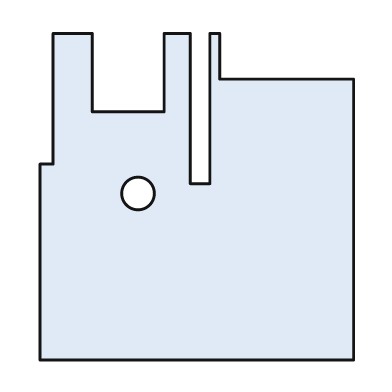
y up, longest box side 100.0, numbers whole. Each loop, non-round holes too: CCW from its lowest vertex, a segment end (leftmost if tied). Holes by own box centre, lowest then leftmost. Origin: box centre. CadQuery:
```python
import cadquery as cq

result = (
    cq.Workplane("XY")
    .moveTo(-48.0, -50.0)
    .lineTo(48.0, -50.0)
    .lineTo(48.0, 36.0)
    .lineTo(7.0, 36.0)
    .lineTo(7.0, 50.0)
    .lineTo(4.0, 50.0)
    .lineTo(4.0, 4.0)
    .lineTo(-2.0, 4.0)
    .lineTo(-2.0, 50.0)
    .lineTo(-10.0, 50.0)
    .lineTo(-10.0, 26.0)
    .lineTo(-32.0, 26.0)
    .lineTo(-32.0, 50.0)
    .lineTo(-44.0, 50.0)
    .lineTo(-44.0, 10.0)
    .lineTo(-48.0, 10.0)
    .close()
    .moveTo(-18.0, 1.0)
    .circle(5.0)
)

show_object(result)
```